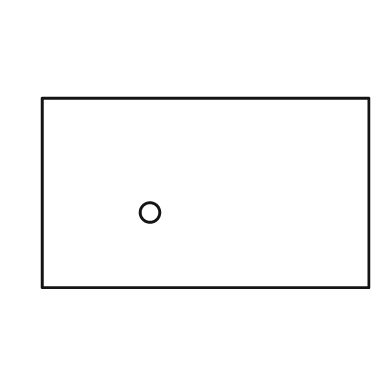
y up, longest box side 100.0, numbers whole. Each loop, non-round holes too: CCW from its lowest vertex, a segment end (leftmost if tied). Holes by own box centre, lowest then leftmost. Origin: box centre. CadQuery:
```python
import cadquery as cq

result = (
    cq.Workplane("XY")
    .moveTo(-50.0, -29.0)
    .lineTo(50.0, -29.0)
    .lineTo(50.0, 29.0)
    .lineTo(-50.0, 29.0)
    .close()
    .moveTo(-17.0, -6.0)
    .circle(3.0)
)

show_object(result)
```